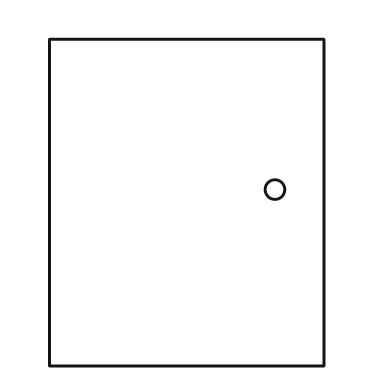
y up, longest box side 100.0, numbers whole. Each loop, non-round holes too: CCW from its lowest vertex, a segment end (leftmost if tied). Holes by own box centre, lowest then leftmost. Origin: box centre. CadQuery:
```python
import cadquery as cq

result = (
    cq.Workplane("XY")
    .moveTo(-42.0, -50.0)
    .lineTo(42.0, -50.0)
    .lineTo(42.0, 50.0)
    .lineTo(-42.0, 50.0)
    .close()
    .moveTo(27.0, 4.0)
    .circle(3.0)
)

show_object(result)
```